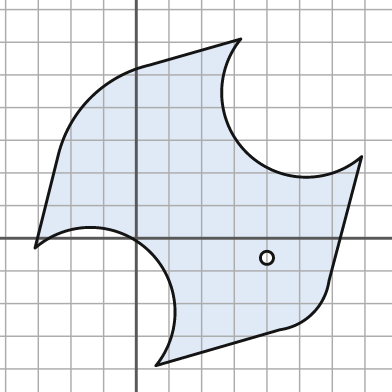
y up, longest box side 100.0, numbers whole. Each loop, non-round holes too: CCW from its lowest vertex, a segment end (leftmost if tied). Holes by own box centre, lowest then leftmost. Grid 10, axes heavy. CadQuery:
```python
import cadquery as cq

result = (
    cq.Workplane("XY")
    .moveTo(6.0, -39.0)
    .lineTo(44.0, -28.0)
    .threePointArc((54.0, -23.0), (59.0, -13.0))
    .lineTo(69.0, 25.0)
    .threePointArc((34.0, 26.0), (32.0, 61.0))
    .lineTo(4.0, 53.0)
    .threePointArc((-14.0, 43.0), (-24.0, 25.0))
    .lineTo(-31.0, -3.0)
    .threePointArc((4.0, -4.0), (6.0, -39.0))
    .close()
    .moveTo(40.0, -6.0)
    .circle(2.0)
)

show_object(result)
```